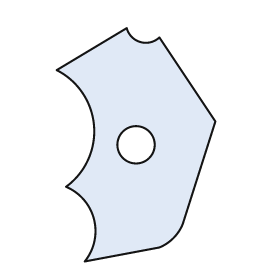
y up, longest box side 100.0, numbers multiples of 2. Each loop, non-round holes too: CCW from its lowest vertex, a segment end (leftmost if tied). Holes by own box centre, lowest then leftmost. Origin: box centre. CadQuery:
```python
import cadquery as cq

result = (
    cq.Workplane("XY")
    .moveTo(-22.0, -50.0)
    .lineTo(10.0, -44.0)
    .threePointArc((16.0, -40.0), (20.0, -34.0))
    .lineTo(34.0, 10.0)
    .lineTo(10.0, 46.0)
    .threePointArc((2.0, 44.0), (-4.0, 50.0))
    .lineTo(-34.0, 32.0)
    .threePointArc((-18.0, 8.0), (-30.0, -18.0))
    .threePointArc((-18.0, -32.0), (-22.0, -50.0))
    .close()
    .moveTo(0.0, 0.0)
    .circle(8.0)
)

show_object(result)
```